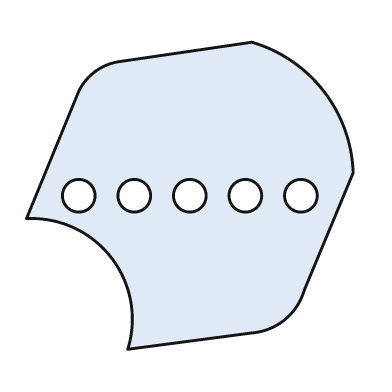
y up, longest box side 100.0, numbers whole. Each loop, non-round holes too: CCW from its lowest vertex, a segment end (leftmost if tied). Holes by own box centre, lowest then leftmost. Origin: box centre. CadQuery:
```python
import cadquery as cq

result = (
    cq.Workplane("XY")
    .moveTo(-19.0, -47.0)
    .lineTo(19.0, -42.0)
    .threePointArc((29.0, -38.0), (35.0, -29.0))
    .lineTo(50.0, 7.0)
    .threePointArc((41.0, 32.0), (19.0, 47.0))
    .lineTo(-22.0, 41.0)
    .threePointArc((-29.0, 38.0), (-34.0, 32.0))
    .lineTo(-50.0, -7.0)
    .threePointArc((-24.0, -19.0), (-19.0, -47.0))
    .close()
    .moveTo(-34.0, 0.0)
    .circle(5.0)
    .moveTo(-17.0, 0.0)
    .circle(5.0)
    .moveTo(0.0, 0.0)
    .circle(5.0)
    .moveTo(17.0, 0.0)
    .circle(5.0)
    .moveTo(34.0, 0.0)
    .circle(5.0)
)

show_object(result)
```